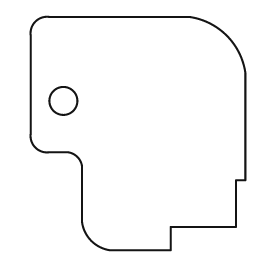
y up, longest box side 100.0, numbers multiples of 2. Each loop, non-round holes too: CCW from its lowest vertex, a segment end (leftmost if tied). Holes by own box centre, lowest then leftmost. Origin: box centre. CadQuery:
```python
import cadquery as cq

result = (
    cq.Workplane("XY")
    .moveTo(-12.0, -50.0)
    .lineTo(14.0, -50.0)
    .lineTo(14.0, -40.0)
    .lineTo(42.0, -40.0)
    .lineTo(42.0, -20.0)
    .lineTo(46.0, -20.0)
    .lineTo(46.0, 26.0)
    .threePointArc((38.0, 42.0), (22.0, 50.0))
    .lineTo(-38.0, 50.0)
    .threePointArc((-44.0, 48.0), (-46.0, 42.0))
    .lineTo(-46.0, 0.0)
    .threePointArc((-44.0, -6.0), (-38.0, -8.0))
    .lineTo(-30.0, -8.0)
    .threePointArc((-26.0, -10.0), (-24.0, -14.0))
    .lineTo(-24.0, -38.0)
    .threePointArc((-20.0, -46.0), (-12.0, -50.0))
    .close()
    .moveTo(-32.0, 14.0)
    .circle(6.0)
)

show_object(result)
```